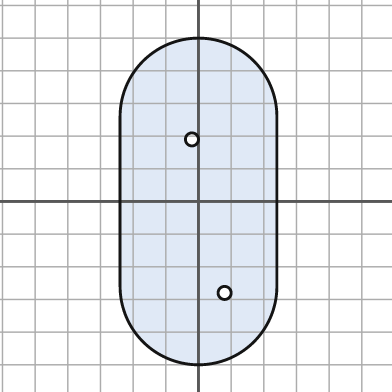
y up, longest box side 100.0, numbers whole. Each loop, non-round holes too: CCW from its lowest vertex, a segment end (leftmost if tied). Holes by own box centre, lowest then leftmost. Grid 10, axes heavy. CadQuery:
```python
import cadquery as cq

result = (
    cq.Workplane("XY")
    .moveTo(-24.0, -26.0)
    .threePointArc((0.0, -50.0), (24.0, -26.0))
    .lineTo(24.0, 26.0)
    .threePointArc((0.0, 50.0), (-24.0, 26.0))
    .close()
    .moveTo(8.0, -28.0)
    .circle(2.0)
    .moveTo(-2.0, 19.0)
    .circle(2.0)
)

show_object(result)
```